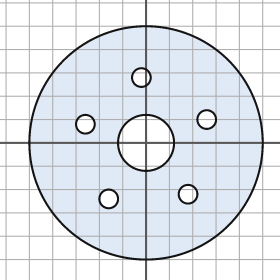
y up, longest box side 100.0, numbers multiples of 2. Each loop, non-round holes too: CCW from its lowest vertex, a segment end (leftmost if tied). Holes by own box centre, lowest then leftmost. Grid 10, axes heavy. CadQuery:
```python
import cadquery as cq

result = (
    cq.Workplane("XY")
    .moveTo(0.0, 0.0)
    .circle(50.0)
    .moveTo(-16.0, -24.0)
    .circle(4.0)
    .moveTo(18.0, -22.0)
    .circle(4.0)
    .moveTo(0.0, 0.0)
    .circle(12.0)
    .moveTo(-26.0, 8.0)
    .circle(4.0)
    .moveTo(26.0, 10.0)
    .circle(4.0)
    .moveTo(-2.0, 28.0)
    .circle(4.0)
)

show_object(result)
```